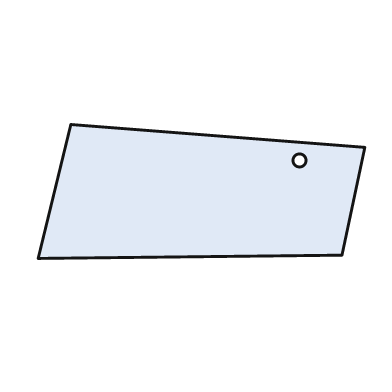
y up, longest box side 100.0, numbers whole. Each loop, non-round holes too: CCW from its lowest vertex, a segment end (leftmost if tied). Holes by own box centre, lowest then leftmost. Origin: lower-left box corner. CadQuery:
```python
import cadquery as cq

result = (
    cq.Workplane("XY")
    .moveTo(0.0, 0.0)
    .lineTo(93.0, 1.0)
    .lineTo(100.0, 34.0)
    .lineTo(10.0, 41.0)
    .close()
    .moveTo(80.0, 30.0)
    .circle(2.0)
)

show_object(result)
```